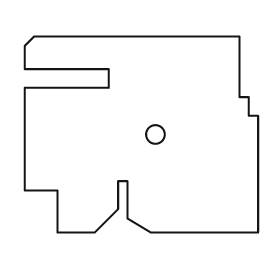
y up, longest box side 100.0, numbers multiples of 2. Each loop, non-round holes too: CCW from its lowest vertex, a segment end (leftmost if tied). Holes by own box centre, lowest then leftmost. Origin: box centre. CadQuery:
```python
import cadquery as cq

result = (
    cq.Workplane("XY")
    .moveTo(-36.0, -42.0)
    .lineTo(-20.0, -42.0)
    .lineTo(-10.0, -32.0)
    .lineTo(-10.0, -20.0)
    .lineTo(-6.0, -20.0)
    .lineTo(-6.0, -36.0)
    .lineTo(4.0, -42.0)
    .lineTo(50.0, -42.0)
    .lineTo(50.0, 8.0)
    .lineTo(46.0, 8.0)
    .lineTo(46.0, 16.0)
    .lineTo(42.0, 16.0)
    .lineTo(42.0, 42.0)
    .lineTo(-46.0, 42.0)
    .lineTo(-50.0, 38.0)
    .lineTo(-50.0, 28.0)
    .lineTo(-14.0, 28.0)
    .lineTo(-14.0, 20.0)
    .lineTo(-50.0, 20.0)
    .lineTo(-50.0, -24.0)
    .lineTo(-36.0, -24.0)
    .close()
    .moveTo(6.0, 0.0)
    .circle(4.0)
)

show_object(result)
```